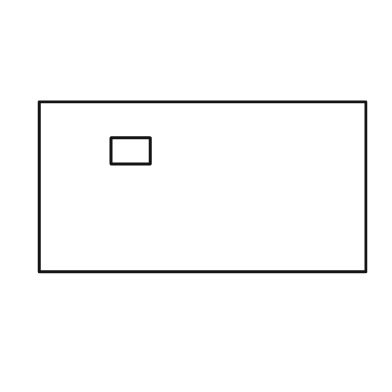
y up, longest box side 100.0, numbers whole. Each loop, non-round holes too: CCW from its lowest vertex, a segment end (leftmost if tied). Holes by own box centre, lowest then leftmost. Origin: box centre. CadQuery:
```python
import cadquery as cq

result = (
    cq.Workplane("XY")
    .moveTo(-50.0, -26.0)
    .lineTo(50.0, -26.0)
    .lineTo(50.0, 26.0)
    .lineTo(-50.0, 26.0)
    .close()
    .moveTo(-28.0, 7.0)
    .lineTo(-16.0, 7.0)
    .lineTo(-16.0, 15.0)
    .lineTo(-28.0, 15.0)
    .close()
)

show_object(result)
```